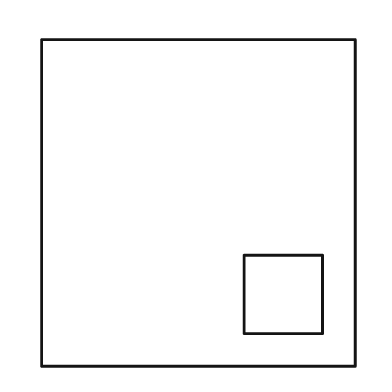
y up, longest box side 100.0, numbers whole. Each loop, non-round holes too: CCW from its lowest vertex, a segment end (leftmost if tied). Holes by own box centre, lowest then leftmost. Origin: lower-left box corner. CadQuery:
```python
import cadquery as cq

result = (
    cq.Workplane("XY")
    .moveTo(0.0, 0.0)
    .lineTo(96.0, 0.0)
    .lineTo(96.0, 100.0)
    .lineTo(0.0, 100.0)
    .close()
    .moveTo(62.0, 10.0)
    .lineTo(86.0, 10.0)
    .lineTo(86.0, 34.0)
    .lineTo(62.0, 34.0)
    .close()
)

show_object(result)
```